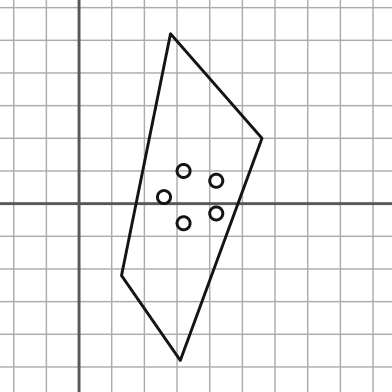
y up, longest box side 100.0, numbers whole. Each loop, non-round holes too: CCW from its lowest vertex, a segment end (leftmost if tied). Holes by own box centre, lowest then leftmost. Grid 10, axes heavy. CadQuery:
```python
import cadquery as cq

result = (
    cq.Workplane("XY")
    .moveTo(31.0, -48.0)
    .lineTo(56.0, 20.0)
    .lineTo(28.0, 52.0)
    .lineTo(13.0, -22.0)
    .close()
    .moveTo(32.0, -6.0)
    .circle(2.0)
    .moveTo(42.0, -3.0)
    .circle(2.0)
    .moveTo(26.0, 2.0)
    .circle(2.0)
    .moveTo(42.0, 7.0)
    .circle(2.0)
    .moveTo(32.0, 10.0)
    .circle(2.0)
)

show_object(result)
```